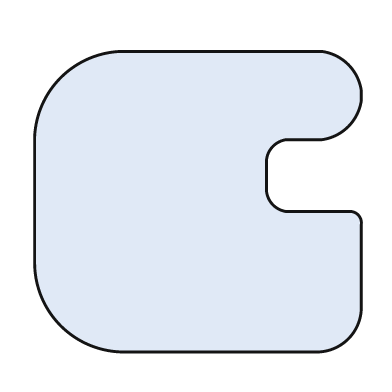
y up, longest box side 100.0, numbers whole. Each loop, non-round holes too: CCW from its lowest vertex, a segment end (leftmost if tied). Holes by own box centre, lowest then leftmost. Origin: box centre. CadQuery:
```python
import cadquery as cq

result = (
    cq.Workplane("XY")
    .moveTo(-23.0, -46.0)
    .lineTo(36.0, -46.0)
    .threePointArc((46.0, -42.0), (50.0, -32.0))
    .lineTo(50.0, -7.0)
    .threePointArc((49.0, -4.0), (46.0, -3.0))
    .lineTo(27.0, -3.0)
    .threePointArc((23.0, -1.0), (21.0, 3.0))
    .lineTo(21.0, 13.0)
    .threePointArc((23.0, 17.0), (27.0, 19.0))
    .lineTo(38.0, 19.0)
    .threePointArc((46.0, 23.0), (50.0, 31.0))
    .lineTo(50.0, 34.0)
    .threePointArc((46.0, 42.0), (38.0, 46.0))
    .lineTo(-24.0, 46.0)
    .threePointArc((-42.0, 38.0), (-50.0, 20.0))
    .lineTo(-50.0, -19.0)
    .threePointArc((-42.0, -38.0), (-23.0, -46.0))
    .close()
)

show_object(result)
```